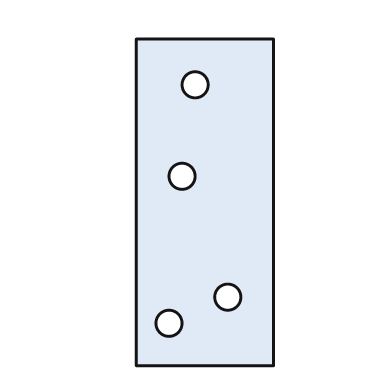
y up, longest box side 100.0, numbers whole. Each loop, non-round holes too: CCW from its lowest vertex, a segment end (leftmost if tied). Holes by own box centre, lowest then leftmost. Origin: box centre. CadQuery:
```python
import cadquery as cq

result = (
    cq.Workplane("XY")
    .moveTo(-21.0, -50.0)
    .lineTo(21.0, -50.0)
    .lineTo(21.0, 50.0)
    .lineTo(-21.0, 50.0)
    .close()
    .moveTo(-11.0, -37.0)
    .circle(4.0)
    .moveTo(7.0, -29.0)
    .circle(4.0)
    .moveTo(-7.0, 8.0)
    .circle(4.0)
    .moveTo(-3.0, 36.0)
    .circle(4.0)
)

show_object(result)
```